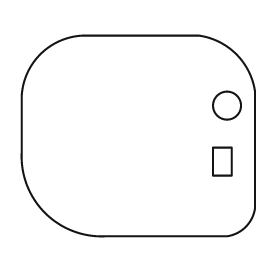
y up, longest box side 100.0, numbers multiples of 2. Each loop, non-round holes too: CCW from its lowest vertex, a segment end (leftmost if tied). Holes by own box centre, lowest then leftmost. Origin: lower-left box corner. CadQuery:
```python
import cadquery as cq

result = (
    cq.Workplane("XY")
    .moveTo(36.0, 0.0)
    .lineTo(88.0, 0.0)
    .threePointArc((96.0, 4.0), (100.0, 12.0))
    .lineTo(100.0, 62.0)
    .threePointArc((92.0, 78.0), (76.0, 86.0))
    .lineTo(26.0, 86.0)
    .threePointArc((8.0, 78.0), (0.0, 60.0))
    .lineTo(0.0, 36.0)
    .threePointArc((10.0, 10.0), (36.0, 0.0))
    .close()
    .moveTo(82.0, 26.0)
    .lineTo(90.0, 26.0)
    .lineTo(90.0, 38.0)
    .lineTo(82.0, 38.0)
    .close()
    .moveTo(88.0, 56.0)
    .circle(6.0)
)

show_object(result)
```